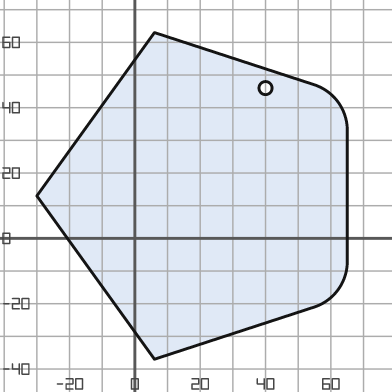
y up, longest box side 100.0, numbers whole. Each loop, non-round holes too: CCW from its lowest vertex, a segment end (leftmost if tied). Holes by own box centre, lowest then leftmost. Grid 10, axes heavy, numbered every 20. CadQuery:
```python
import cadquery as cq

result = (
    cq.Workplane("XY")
    .moveTo(6.0, -37.0)
    .lineTo(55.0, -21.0)
    .threePointArc((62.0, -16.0), (65.0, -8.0))
    .lineTo(65.0, 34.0)
    .threePointArc((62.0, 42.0), (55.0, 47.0))
    .lineTo(6.0, 63.0)
    .lineTo(-30.0, 13.0)
    .close()
    .moveTo(40.0, 46.0)
    .circle(2.0)
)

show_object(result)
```